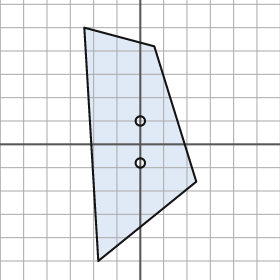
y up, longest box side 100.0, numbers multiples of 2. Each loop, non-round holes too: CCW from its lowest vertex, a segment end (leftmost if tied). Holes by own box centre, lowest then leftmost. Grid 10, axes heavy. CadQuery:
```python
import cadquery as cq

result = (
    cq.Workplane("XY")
    .moveTo(-18.0, -50.0)
    .lineTo(24.0, -16.0)
    .lineTo(6.0, 42.0)
    .lineTo(-24.0, 50.0)
    .close()
    .moveTo(0.0, -8.0)
    .circle(2.0)
    .moveTo(0.0, 10.0)
    .circle(2.0)
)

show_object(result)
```